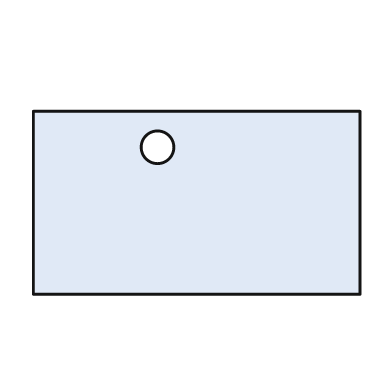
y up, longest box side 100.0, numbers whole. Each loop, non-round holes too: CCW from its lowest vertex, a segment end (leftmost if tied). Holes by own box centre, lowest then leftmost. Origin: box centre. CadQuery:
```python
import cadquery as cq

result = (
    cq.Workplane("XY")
    .moveTo(-50.0, -28.0)
    .lineTo(50.0, -28.0)
    .lineTo(50.0, 28.0)
    .lineTo(-50.0, 28.0)
    .close()
    .moveTo(-12.0, 17.0)
    .circle(5.0)
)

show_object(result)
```